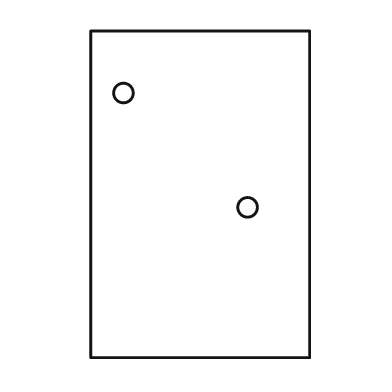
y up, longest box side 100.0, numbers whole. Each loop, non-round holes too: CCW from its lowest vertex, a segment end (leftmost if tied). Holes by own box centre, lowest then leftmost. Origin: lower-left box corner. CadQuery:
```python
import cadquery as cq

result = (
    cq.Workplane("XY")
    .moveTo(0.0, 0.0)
    .lineTo(67.0, 0.0)
    .lineTo(67.0, 100.0)
    .lineTo(0.0, 100.0)
    .close()
    .moveTo(48.0, 46.0)
    .circle(3.0)
    .moveTo(10.0, 81.0)
    .circle(3.0)
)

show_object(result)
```